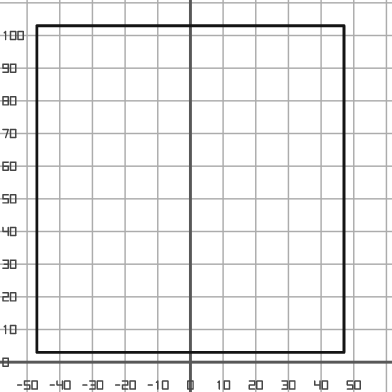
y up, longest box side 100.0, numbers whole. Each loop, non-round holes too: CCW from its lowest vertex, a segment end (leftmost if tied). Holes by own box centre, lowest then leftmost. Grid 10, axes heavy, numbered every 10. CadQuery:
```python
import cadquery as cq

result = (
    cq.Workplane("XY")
    .moveTo(-47.0, 3.0)
    .lineTo(47.0, 3.0)
    .lineTo(47.0, 103.0)
    .lineTo(-47.0, 103.0)
    .close()
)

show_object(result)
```